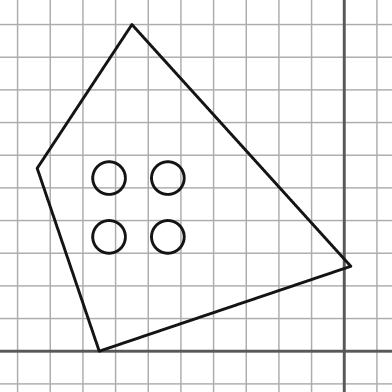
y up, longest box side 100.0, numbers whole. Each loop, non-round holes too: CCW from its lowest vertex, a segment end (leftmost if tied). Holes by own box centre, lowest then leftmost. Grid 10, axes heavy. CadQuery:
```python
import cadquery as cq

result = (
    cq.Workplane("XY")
    .moveTo(-75.0, 0.0)
    .lineTo(2.0, 26.0)
    .lineTo(-65.0, 100.0)
    .lineTo(-94.0, 56.0)
    .close()
    .moveTo(-72.0, 35.0)
    .circle(5.0)
    .moveTo(-54.0, 35.0)
    .circle(5.0)
    .moveTo(-72.0, 53.0)
    .circle(5.0)
    .moveTo(-54.0, 53.0)
    .circle(5.0)
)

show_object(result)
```